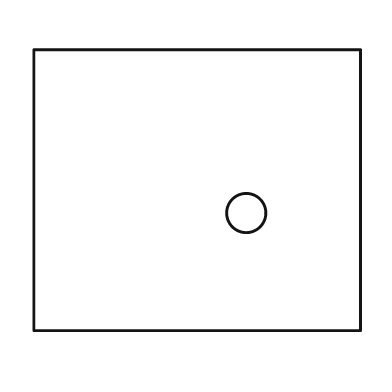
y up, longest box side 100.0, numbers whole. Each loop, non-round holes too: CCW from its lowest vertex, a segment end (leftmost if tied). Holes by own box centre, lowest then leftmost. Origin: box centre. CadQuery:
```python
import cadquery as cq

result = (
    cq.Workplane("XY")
    .moveTo(-50.0, -43.0)
    .lineTo(50.0, -43.0)
    .lineTo(50.0, 43.0)
    .lineTo(-50.0, 43.0)
    .close()
    .moveTo(15.0, -7.0)
    .circle(6.0)
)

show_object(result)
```